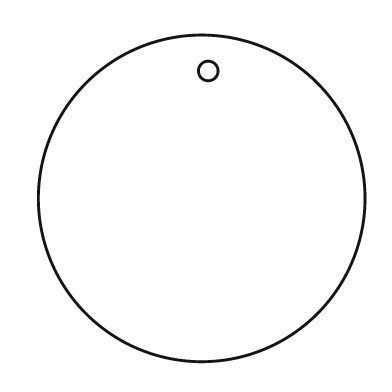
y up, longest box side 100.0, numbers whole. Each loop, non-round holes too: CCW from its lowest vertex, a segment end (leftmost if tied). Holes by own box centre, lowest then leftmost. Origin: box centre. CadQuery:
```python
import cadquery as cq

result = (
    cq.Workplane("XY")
    .moveTo(0.0, 0.0)
    .circle(50.0)
    .moveTo(2.0, 39.0)
    .circle(3.0)
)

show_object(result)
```